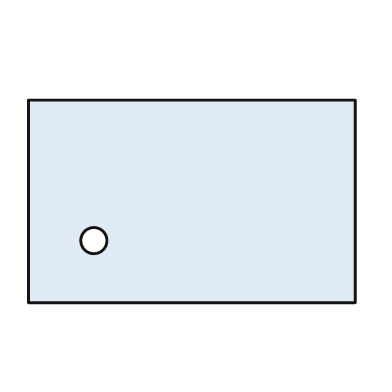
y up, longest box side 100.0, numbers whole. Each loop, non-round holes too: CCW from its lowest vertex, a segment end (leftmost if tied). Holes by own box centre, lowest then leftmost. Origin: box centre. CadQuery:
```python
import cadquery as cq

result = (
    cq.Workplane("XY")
    .moveTo(-50.0, -31.0)
    .lineTo(50.0, -31.0)
    .lineTo(50.0, 31.0)
    .lineTo(-50.0, 31.0)
    .close()
    .moveTo(-30.0, -12.0)
    .circle(4.0)
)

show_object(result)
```